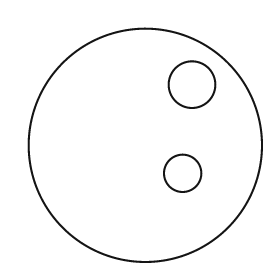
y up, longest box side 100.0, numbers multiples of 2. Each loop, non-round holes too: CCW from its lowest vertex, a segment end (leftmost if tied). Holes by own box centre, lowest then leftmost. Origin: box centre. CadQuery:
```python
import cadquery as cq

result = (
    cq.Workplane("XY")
    .moveTo(0.0, 0.0)
    .circle(50.0)
    .moveTo(16.0, -12.0)
    .circle(8.0)
    .moveTo(20.0, 26.0)
    .circle(10.0)
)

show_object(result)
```